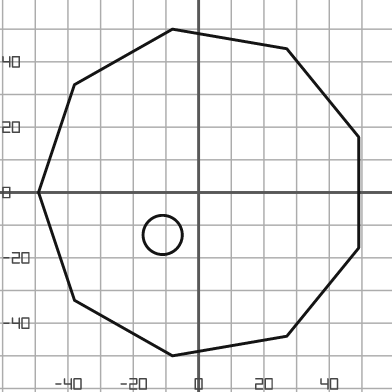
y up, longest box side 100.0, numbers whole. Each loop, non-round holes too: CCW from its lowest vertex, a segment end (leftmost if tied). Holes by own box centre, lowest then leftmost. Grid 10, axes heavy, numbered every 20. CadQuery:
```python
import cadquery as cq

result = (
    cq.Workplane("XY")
    .moveTo(-8.0, -50.0)
    .lineTo(27.0, -44.0)
    .lineTo(49.0, -17.0)
    .lineTo(49.0, 17.0)
    .lineTo(27.0, 44.0)
    .lineTo(-8.0, 50.0)
    .lineTo(-38.0, 33.0)
    .lineTo(-49.0, 0.0)
    .lineTo(-38.0, -33.0)
    .close()
    .moveTo(-11.0, -13.0)
    .circle(6.0)
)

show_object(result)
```